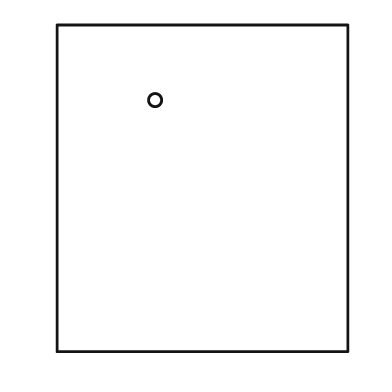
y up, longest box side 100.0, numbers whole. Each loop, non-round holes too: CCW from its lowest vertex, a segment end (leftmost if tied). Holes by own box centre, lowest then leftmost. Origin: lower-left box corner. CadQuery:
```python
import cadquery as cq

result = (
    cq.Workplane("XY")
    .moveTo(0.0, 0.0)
    .lineTo(89.0, 0.0)
    .lineTo(89.0, 100.0)
    .lineTo(0.0, 100.0)
    .close()
    .moveTo(30.0, 77.0)
    .circle(2.0)
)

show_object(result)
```